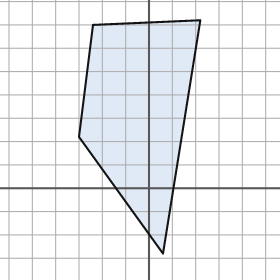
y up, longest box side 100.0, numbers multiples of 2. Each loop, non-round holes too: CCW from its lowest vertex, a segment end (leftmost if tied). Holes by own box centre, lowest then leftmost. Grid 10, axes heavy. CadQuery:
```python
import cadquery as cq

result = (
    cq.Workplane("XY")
    .moveTo(6.0, -28.0)
    .lineTo(22.0, 72.0)
    .lineTo(-24.0, 70.0)
    .lineTo(-30.0, 22.0)
    .close()
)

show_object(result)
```